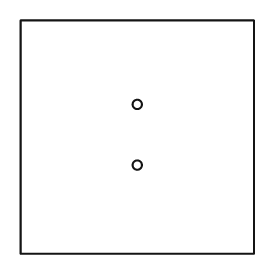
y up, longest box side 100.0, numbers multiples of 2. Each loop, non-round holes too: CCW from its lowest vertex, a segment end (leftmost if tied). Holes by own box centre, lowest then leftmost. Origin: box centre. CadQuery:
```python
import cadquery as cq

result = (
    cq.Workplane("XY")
    .moveTo(-50.0, -50.0)
    .lineTo(50.0, -50.0)
    .lineTo(50.0, 50.0)
    .lineTo(-50.0, 50.0)
    .close()
    .moveTo(0.0, -12.0)
    .circle(2.0)
    .moveTo(0.0, 14.0)
    .circle(2.0)
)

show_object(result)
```